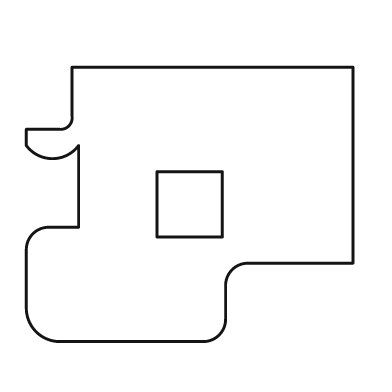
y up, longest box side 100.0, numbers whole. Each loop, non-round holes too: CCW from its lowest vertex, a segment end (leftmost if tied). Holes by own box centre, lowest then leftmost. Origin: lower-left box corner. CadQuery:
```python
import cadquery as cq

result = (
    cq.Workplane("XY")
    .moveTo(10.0, 0.0)
    .lineTo(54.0, 0.0)
    .threePointArc((59.0, 2.0), (61.0, 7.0))
    .lineTo(61.0, 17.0)
    .threePointArc((63.0, 22.0), (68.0, 24.0))
    .lineTo(100.0, 24.0)
    .lineTo(100.0, 84.0)
    .lineTo(14.0, 84.0)
    .lineTo(14.0, 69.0)
    .threePointArc((13.0, 66.0), (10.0, 65.0))
    .lineTo(0.0, 65.0)
    .lineTo(0.0, 60.0)
    .threePointArc((8.0, 56.0), (16.0, 60.0))
    .lineTo(16.0, 35.0)
    .lineTo(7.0, 35.0)
    .threePointArc((2.0, 33.0), (0.0, 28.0))
    .lineTo(0.0, 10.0)
    .threePointArc((3.0, 3.0), (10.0, 0.0))
    .close()
    .moveTo(40.0, 32.0)
    .lineTo(60.0, 32.0)
    .lineTo(60.0, 52.0)
    .lineTo(40.0, 52.0)
    .close()
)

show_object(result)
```